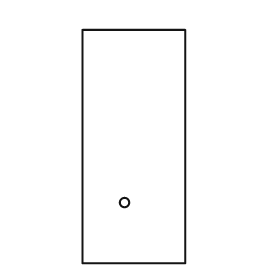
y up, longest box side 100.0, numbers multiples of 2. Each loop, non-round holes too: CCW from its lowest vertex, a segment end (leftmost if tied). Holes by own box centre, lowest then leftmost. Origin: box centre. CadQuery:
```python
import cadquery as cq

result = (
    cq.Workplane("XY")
    .moveTo(-22.0, -50.0)
    .lineTo(22.0, -50.0)
    .lineTo(22.0, 50.0)
    .lineTo(-22.0, 50.0)
    .close()
    .moveTo(-4.0, -24.0)
    .circle(2.0)
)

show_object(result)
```